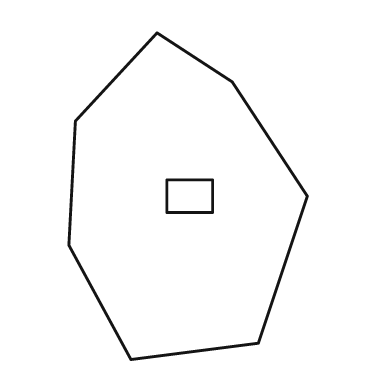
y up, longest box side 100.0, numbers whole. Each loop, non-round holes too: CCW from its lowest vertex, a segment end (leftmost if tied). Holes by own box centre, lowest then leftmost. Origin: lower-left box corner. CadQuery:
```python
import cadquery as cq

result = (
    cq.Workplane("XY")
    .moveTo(19.0, 0.0)
    .lineTo(58.0, 5.0)
    .lineTo(73.0, 50.0)
    .lineTo(50.0, 85.0)
    .lineTo(27.0, 100.0)
    .lineTo(2.0, 73.0)
    .lineTo(0.0, 35.0)
    .close()
    .moveTo(30.0, 45.0)
    .lineTo(44.0, 45.0)
    .lineTo(44.0, 55.0)
    .lineTo(30.0, 55.0)
    .close()
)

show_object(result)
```